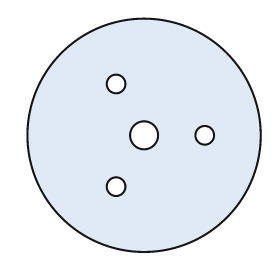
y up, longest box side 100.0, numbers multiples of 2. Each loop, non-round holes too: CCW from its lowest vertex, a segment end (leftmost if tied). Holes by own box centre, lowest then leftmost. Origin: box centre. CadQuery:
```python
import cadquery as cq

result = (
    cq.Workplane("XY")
    .moveTo(0.0, 0.0)
    .circle(50.0)
    .moveTo(-12.0, -22.0)
    .circle(4.0)
    .moveTo(0.0, 0.0)
    .circle(6.0)
    .moveTo(26.0, 0.0)
    .circle(4.0)
    .moveTo(-12.0, 22.0)
    .circle(4.0)
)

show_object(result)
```